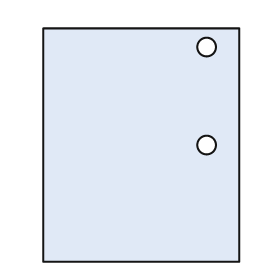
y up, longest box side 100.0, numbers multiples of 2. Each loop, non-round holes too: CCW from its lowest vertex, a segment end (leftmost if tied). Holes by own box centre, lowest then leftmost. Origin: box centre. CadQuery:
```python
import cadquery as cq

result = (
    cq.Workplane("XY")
    .moveTo(-42.0, -50.0)
    .lineTo(42.0, -50.0)
    .lineTo(42.0, 50.0)
    .lineTo(-42.0, 50.0)
    .close()
    .moveTo(28.0, 0.0)
    .circle(4.0)
    .moveTo(28.0, 42.0)
    .circle(4.0)
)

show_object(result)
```